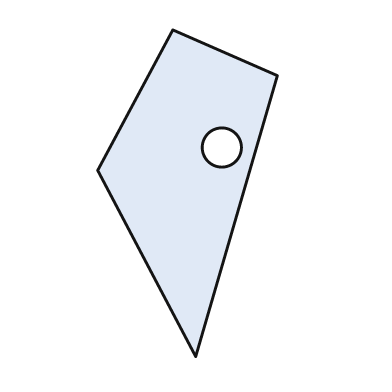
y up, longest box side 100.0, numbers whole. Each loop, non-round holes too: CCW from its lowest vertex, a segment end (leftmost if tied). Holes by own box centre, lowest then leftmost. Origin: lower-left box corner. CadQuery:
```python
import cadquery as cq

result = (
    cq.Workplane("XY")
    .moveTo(30.0, 0.0)
    .lineTo(55.0, 86.0)
    .lineTo(23.0, 100.0)
    .lineTo(0.0, 57.0)
    .close()
    .moveTo(38.0, 64.0)
    .circle(6.0)
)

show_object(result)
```